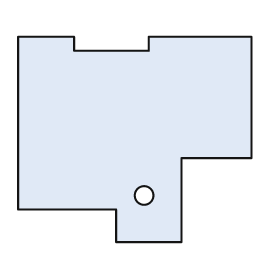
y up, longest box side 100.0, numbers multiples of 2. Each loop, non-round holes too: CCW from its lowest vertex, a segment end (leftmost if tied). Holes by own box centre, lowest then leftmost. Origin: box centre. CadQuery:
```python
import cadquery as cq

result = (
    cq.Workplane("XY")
    .moveTo(-8.0, -44.0)
    .lineTo(20.0, -44.0)
    .lineTo(20.0, -8.0)
    .lineTo(50.0, -8.0)
    .lineTo(50.0, 44.0)
    .lineTo(6.0, 44.0)
    .lineTo(6.0, 38.0)
    .lineTo(-26.0, 38.0)
    .lineTo(-26.0, 44.0)
    .lineTo(-50.0, 44.0)
    .lineTo(-50.0, -30.0)
    .lineTo(-8.0, -30.0)
    .close()
    .moveTo(4.0, -24.0)
    .circle(4.0)
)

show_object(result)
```